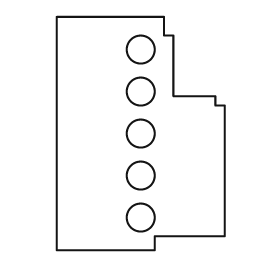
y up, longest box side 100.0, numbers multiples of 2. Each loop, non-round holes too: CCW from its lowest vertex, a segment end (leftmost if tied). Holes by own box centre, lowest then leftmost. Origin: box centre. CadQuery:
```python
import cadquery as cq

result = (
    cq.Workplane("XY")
    .moveTo(-36.0, -50.0)
    .lineTo(6.0, -50.0)
    .lineTo(6.0, -44.0)
    .lineTo(36.0, -44.0)
    .lineTo(36.0, 12.0)
    .lineTo(32.0, 12.0)
    .lineTo(32.0, 16.0)
    .lineTo(14.0, 16.0)
    .lineTo(14.0, 42.0)
    .lineTo(10.0, 42.0)
    .lineTo(10.0, 50.0)
    .lineTo(-36.0, 50.0)
    .close()
    .moveTo(0.0, -36.0)
    .circle(6.0)
    .moveTo(0.0, -18.0)
    .circle(6.0)
    .moveTo(0.0, 0.0)
    .circle(6.0)
    .moveTo(0.0, 18.0)
    .circle(6.0)
    .moveTo(0.0, 36.0)
    .circle(6.0)
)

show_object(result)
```